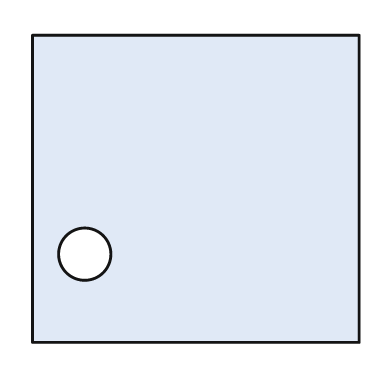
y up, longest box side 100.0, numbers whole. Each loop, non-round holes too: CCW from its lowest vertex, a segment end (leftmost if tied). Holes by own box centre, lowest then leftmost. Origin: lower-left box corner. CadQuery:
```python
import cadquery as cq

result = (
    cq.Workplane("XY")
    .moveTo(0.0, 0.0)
    .lineTo(100.0, 0.0)
    .lineTo(100.0, 94.0)
    .lineTo(0.0, 94.0)
    .close()
    .moveTo(16.0, 27.0)
    .circle(8.0)
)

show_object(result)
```